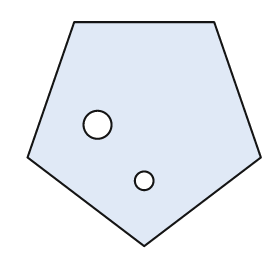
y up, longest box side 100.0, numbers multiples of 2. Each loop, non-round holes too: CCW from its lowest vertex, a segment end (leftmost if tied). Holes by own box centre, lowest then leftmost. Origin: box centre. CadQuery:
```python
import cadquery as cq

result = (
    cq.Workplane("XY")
    .moveTo(0.0, -48.0)
    .lineTo(50.0, -10.0)
    .lineTo(30.0, 48.0)
    .lineTo(-30.0, 48.0)
    .lineTo(-50.0, -10.0)
    .close()
    .moveTo(0.0, -20.0)
    .circle(4.0)
    .moveTo(-20.0, 4.0)
    .circle(6.0)
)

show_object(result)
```